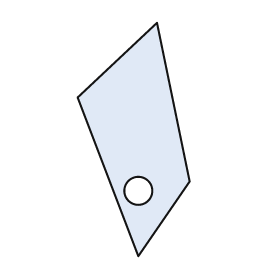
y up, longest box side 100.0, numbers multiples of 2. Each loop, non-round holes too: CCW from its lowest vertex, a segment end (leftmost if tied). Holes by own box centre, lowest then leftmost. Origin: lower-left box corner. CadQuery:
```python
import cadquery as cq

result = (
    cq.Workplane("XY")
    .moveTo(26.0, 0.0)
    .lineTo(48.0, 32.0)
    .lineTo(34.0, 100.0)
    .lineTo(0.0, 68.0)
    .close()
    .moveTo(26.0, 28.0)
    .circle(6.0)
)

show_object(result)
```